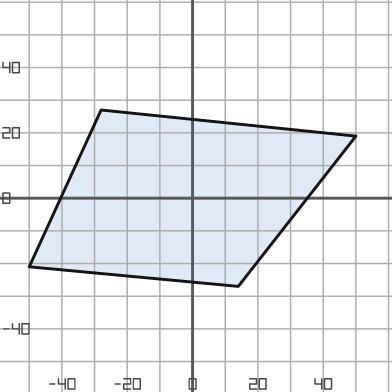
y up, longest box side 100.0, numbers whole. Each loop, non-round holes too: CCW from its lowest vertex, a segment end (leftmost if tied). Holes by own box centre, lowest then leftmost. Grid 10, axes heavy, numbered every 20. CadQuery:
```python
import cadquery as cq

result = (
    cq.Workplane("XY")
    .moveTo(14.0, -27.0)
    .lineTo(50.0, 19.0)
    .lineTo(-28.0, 27.0)
    .lineTo(-50.0, -21.0)
    .close()
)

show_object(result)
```